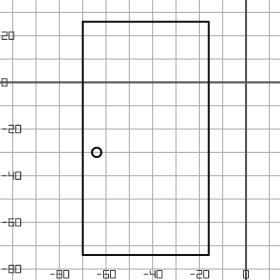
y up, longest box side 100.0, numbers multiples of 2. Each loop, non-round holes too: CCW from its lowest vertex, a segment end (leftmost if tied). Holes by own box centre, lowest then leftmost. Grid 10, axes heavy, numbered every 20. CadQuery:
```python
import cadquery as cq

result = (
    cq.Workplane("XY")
    .moveTo(-70.0, -74.0)
    .lineTo(-16.0, -74.0)
    .lineTo(-16.0, 26.0)
    .lineTo(-70.0, 26.0)
    .close()
    .moveTo(-64.0, -30.0)
    .circle(2.0)
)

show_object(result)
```